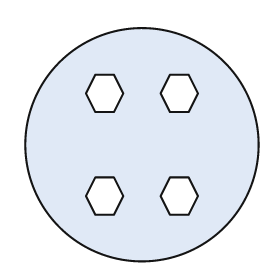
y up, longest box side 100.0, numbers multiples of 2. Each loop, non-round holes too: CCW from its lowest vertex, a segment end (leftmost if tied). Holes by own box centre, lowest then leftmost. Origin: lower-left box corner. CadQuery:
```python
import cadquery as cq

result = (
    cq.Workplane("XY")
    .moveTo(50.0, 50.0)
    .circle(50.0)
    .moveTo(30.0, 20.0)
    .lineTo(38.0, 20.0)
    .lineTo(42.0, 28.0)
    .lineTo(38.0, 36.0)
    .lineTo(30.0, 36.0)
    .lineTo(26.0, 28.0)
    .close()
    .moveTo(62.0, 20.0)
    .lineTo(70.0, 20.0)
    .lineTo(74.0, 28.0)
    .lineTo(70.0, 36.0)
    .lineTo(62.0, 36.0)
    .lineTo(58.0, 28.0)
    .close()
    .moveTo(30.0, 64.0)
    .lineTo(38.0, 64.0)
    .lineTo(42.0, 72.0)
    .lineTo(38.0, 80.0)
    .lineTo(30.0, 80.0)
    .lineTo(26.0, 72.0)
    .close()
    .moveTo(62.0, 64.0)
    .lineTo(70.0, 64.0)
    .lineTo(74.0, 72.0)
    .lineTo(70.0, 80.0)
    .lineTo(62.0, 80.0)
    .lineTo(58.0, 72.0)
    .close()
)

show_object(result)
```